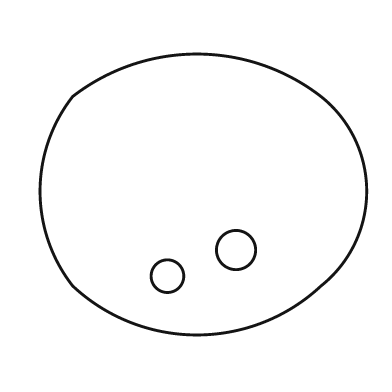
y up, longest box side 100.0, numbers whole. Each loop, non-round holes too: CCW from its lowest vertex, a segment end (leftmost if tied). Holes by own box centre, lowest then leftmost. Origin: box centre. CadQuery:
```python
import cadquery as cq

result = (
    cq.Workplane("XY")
    .moveTo(-40.0, -28.0)
    .threePointArc((-2.0, -43.0), (36.0, -28.0))
    .threePointArc((50.0, 1.0), (36.0, 30.0))
    .threePointArc((-2.0, 43.0), (-40.0, 30.0))
    .threePointArc((-50.0, 1.0), (-40.0, -28.0))
    .close()
    .moveTo(-11.0, -25.0)
    .circle(5.0)
    .moveTo(10.0, -17.0)
    .circle(6.0)
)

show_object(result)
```